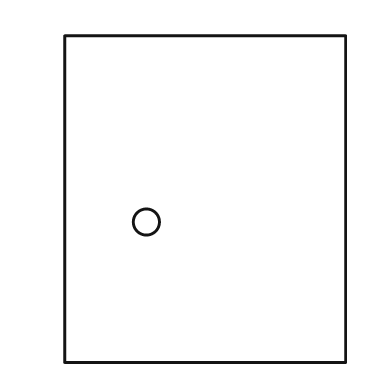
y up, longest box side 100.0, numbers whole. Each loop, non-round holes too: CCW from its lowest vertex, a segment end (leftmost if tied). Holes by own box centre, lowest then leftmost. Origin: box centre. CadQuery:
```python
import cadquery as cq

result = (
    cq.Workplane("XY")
    .moveTo(-43.0, -50.0)
    .lineTo(43.0, -50.0)
    .lineTo(43.0, 50.0)
    .lineTo(-43.0, 50.0)
    .close()
    .moveTo(-18.0, -7.0)
    .circle(4.0)
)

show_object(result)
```